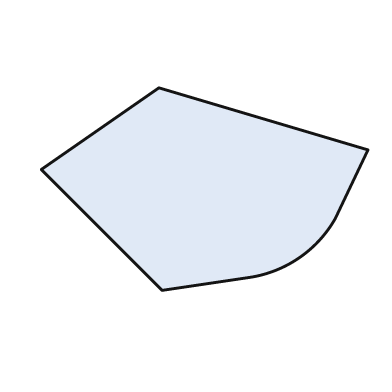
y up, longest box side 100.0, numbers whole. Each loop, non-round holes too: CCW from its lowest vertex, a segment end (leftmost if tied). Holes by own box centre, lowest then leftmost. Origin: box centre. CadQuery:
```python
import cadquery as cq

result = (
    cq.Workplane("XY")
    .moveTo(-13.0, -31.0)
    .lineTo(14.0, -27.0)
    .threePointArc((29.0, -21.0), (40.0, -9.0))
    .lineTo(50.0, 12.0)
    .lineTo(-14.0, 31.0)
    .lineTo(-50.0, 6.0)
    .close()
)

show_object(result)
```